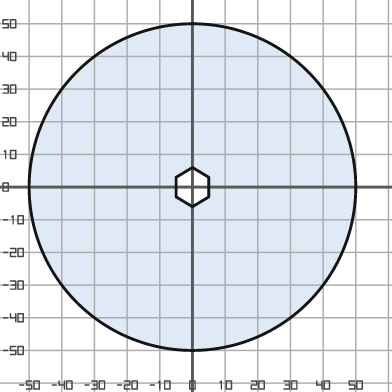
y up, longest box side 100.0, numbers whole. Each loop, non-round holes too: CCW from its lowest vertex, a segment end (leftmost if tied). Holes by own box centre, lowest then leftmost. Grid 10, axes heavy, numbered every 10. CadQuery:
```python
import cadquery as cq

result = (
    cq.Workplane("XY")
    .moveTo(0.0, 0.0)
    .circle(50.0)
    .moveTo(0.0, -6.0)
    .lineTo(5.0, -3.0)
    .lineTo(5.0, 3.0)
    .lineTo(0.0, 6.0)
    .lineTo(-5.0, 3.0)
    .lineTo(-5.0, -3.0)
    .close()
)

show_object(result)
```